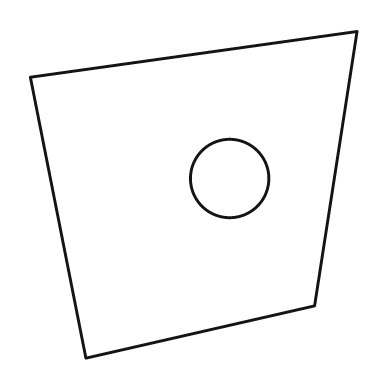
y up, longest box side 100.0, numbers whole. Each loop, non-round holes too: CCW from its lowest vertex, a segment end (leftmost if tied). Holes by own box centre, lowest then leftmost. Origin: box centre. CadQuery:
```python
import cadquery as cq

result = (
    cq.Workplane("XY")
    .moveTo(-33.0, -50.0)
    .lineTo(37.0, -34.0)
    .lineTo(50.0, 50.0)
    .lineTo(-50.0, 36.0)
    .close()
    .moveTo(11.0, 5.0)
    .circle(12.0)
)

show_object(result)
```